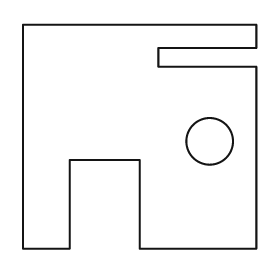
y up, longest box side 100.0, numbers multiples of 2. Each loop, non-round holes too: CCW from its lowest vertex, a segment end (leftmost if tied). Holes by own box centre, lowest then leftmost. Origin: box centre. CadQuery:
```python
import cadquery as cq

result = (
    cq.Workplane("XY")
    .moveTo(-50.0, -48.0)
    .lineTo(-30.0, -48.0)
    .lineTo(-30.0, -10.0)
    .lineTo(0.0, -10.0)
    .lineTo(0.0, -48.0)
    .lineTo(50.0, -48.0)
    .lineTo(50.0, 30.0)
    .lineTo(8.0, 30.0)
    .lineTo(8.0, 38.0)
    .lineTo(50.0, 38.0)
    .lineTo(50.0, 48.0)
    .lineTo(-50.0, 48.0)
    .close()
    .moveTo(30.0, -2.0)
    .circle(10.0)
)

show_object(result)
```